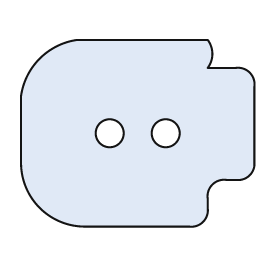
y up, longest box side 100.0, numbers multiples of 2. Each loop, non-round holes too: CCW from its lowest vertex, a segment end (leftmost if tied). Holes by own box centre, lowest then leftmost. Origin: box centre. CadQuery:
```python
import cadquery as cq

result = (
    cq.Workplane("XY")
    .moveTo(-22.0, -40.0)
    .lineTo(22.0, -40.0)
    .threePointArc((28.0, -38.0), (30.0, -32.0))
    .lineTo(30.0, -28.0)
    .threePointArc((32.0, -22.0), (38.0, -20.0))
    .lineTo(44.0, -20.0)
    .threePointArc((48.0, -18.0), (50.0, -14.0))
    .lineTo(50.0, 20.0)
    .threePointArc((48.0, 26.0), (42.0, 28.0))
    .lineTo(30.0, 28.0)
    .threePointArc((32.0, 34.0), (30.0, 40.0))
    .lineTo(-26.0, 40.0)
    .threePointArc((-42.0, 32.0), (-50.0, 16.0))
    .lineTo(-50.0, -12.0)
    .threePointArc((-42.0, -32.0), (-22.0, -40.0))
    .close()
    .moveTo(-12.0, 0.0)
    .circle(6.0)
    .moveTo(12.0, 0.0)
    .circle(6.0)
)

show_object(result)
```